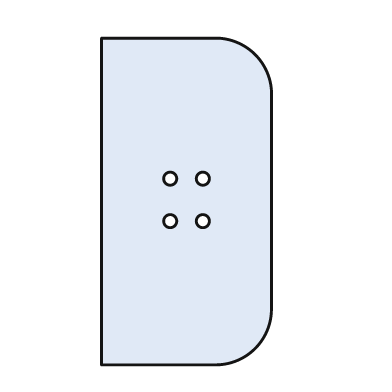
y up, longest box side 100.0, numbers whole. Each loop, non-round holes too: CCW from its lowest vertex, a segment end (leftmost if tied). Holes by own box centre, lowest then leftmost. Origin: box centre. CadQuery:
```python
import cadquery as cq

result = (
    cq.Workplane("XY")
    .moveTo(-26.0, -50.0)
    .lineTo(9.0, -50.0)
    .threePointArc((21.0, -45.0), (26.0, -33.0))
    .lineTo(26.0, 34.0)
    .threePointArc((21.0, 45.0), (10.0, 50.0))
    .lineTo(-26.0, 50.0)
    .close()
    .moveTo(-5.0, -6.0)
    .circle(2.0)
    .moveTo(5.0, -6.0)
    .circle(2.0)
    .moveTo(-5.0, 7.0)
    .circle(2.0)
    .moveTo(5.0, 7.0)
    .circle(2.0)
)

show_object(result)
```